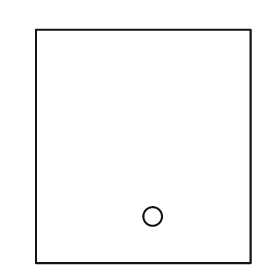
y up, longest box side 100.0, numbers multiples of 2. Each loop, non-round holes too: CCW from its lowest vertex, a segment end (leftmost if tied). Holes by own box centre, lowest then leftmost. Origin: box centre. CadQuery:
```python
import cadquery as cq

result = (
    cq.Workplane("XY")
    .moveTo(-46.0, -50.0)
    .lineTo(46.0, -50.0)
    .lineTo(46.0, 50.0)
    .lineTo(-46.0, 50.0)
    .close()
    .moveTo(4.0, -30.0)
    .circle(4.0)
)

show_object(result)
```